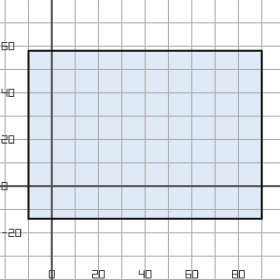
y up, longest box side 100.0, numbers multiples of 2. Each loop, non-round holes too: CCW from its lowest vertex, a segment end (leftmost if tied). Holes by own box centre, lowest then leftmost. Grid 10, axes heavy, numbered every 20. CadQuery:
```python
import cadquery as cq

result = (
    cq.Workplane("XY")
    .moveTo(-10.0, -14.0)
    .lineTo(90.0, -14.0)
    .lineTo(90.0, 58.0)
    .lineTo(-10.0, 58.0)
    .close()
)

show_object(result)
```